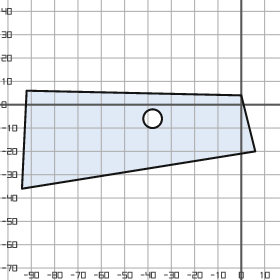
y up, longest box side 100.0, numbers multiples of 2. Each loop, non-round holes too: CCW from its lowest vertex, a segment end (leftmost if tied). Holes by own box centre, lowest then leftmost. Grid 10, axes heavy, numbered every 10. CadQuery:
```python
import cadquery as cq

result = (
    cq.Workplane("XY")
    .moveTo(-94.0, -36.0)
    .lineTo(6.0, -20.0)
    .lineTo(0.0, 4.0)
    .lineTo(-92.0, 6.0)
    .close()
    .moveTo(-38.0, -6.0)
    .circle(4.0)
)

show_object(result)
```